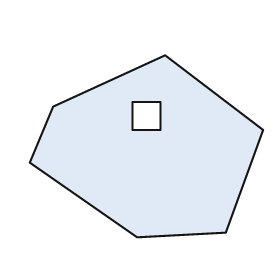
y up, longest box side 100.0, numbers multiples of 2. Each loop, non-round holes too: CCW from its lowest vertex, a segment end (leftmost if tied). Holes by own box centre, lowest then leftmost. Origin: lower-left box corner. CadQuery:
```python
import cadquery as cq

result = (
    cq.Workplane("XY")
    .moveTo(46.0, 0.0)
    .lineTo(84.0, 2.0)
    .lineTo(100.0, 46.0)
    .lineTo(58.0, 78.0)
    .lineTo(10.0, 56.0)
    .lineTo(0.0, 32.0)
    .close()
    .moveTo(44.0, 46.0)
    .lineTo(56.0, 46.0)
    .lineTo(56.0, 58.0)
    .lineTo(44.0, 58.0)
    .close()
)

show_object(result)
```